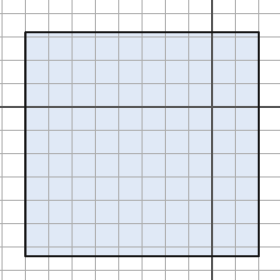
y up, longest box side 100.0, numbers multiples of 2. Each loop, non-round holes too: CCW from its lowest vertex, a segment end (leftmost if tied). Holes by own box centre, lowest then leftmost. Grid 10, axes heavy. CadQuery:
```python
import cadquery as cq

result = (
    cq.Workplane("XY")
    .moveTo(-80.0, -64.0)
    .lineTo(20.0, -64.0)
    .lineTo(20.0, 32.0)
    .lineTo(-80.0, 32.0)
    .close()
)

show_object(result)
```